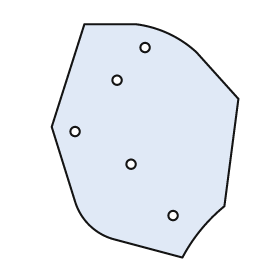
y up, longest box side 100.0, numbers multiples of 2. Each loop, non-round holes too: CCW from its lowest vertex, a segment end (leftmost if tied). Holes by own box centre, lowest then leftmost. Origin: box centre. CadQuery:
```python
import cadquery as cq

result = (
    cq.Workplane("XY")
    .moveTo(16.0, -50.0)
    .threePointArc((24.0, -38.0), (34.0, -28.0))
    .lineTo(40.0, 18.0)
    .lineTo(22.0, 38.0)
    .threePointArc((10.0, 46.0), (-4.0, 50.0))
    .lineTo(-26.0, 50.0)
    .lineTo(-40.0, 6.0)
    .lineTo(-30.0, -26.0)
    .threePointArc((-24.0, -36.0), (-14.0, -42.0))
    .close()
    .moveTo(12.0, -32.0)
    .circle(2.0)
    .moveTo(-6.0, -10.0)
    .circle(2.0)
    .moveTo(-30.0, 4.0)
    .circle(2.0)
    .moveTo(-12.0, 26.0)
    .circle(2.0)
    .moveTo(0.0, 40.0)
    .circle(2.0)
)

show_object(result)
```